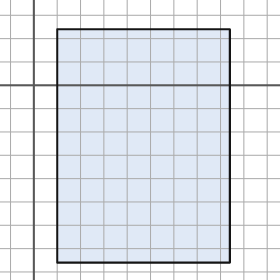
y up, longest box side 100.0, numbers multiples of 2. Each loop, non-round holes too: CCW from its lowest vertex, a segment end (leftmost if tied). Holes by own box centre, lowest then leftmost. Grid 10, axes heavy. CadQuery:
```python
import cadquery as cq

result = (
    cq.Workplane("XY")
    .moveTo(10.0, -76.0)
    .lineTo(84.0, -76.0)
    .lineTo(84.0, 24.0)
    .lineTo(10.0, 24.0)
    .close()
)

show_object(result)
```